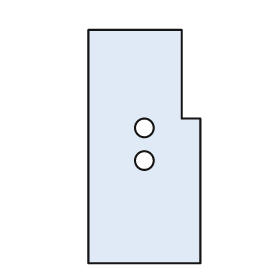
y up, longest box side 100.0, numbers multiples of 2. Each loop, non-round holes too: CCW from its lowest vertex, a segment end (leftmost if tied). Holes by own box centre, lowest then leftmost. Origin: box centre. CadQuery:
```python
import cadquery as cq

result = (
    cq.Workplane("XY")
    .moveTo(-24.0, -50.0)
    .lineTo(24.0, -50.0)
    .lineTo(24.0, 12.0)
    .lineTo(16.0, 12.0)
    .lineTo(16.0, 50.0)
    .lineTo(-24.0, 50.0)
    .close()
    .moveTo(0.0, -6.0)
    .circle(4.0)
    .moveTo(0.0, 8.0)
    .circle(4.0)
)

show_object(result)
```